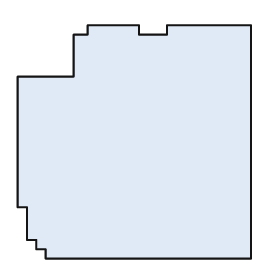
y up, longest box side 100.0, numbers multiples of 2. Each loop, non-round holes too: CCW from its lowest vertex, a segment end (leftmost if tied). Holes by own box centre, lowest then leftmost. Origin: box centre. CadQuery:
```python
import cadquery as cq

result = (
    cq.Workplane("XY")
    .moveTo(-38.0, -50.0)
    .lineTo(50.0, -50.0)
    .lineTo(50.0, 50.0)
    .lineTo(14.0, 50.0)
    .lineTo(14.0, 46.0)
    .lineTo(2.0, 46.0)
    .lineTo(2.0, 50.0)
    .lineTo(-20.0, 50.0)
    .lineTo(-20.0, 46.0)
    .lineTo(-26.0, 46.0)
    .lineTo(-26.0, 28.0)
    .lineTo(-50.0, 28.0)
    .lineTo(-50.0, -28.0)
    .lineTo(-46.0, -28.0)
    .lineTo(-46.0, -42.0)
    .lineTo(-42.0, -42.0)
    .lineTo(-42.0, -46.0)
    .lineTo(-38.0, -46.0)
    .close()
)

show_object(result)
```